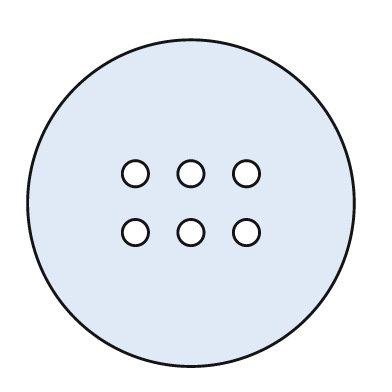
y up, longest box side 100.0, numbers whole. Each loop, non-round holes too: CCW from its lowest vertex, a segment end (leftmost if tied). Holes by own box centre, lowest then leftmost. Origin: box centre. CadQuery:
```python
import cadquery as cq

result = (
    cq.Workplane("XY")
    .moveTo(0.0, 0.0)
    .circle(50.0)
    .moveTo(-17.0, -9.0)
    .circle(4.0)
    .moveTo(0.0, -9.0)
    .circle(4.0)
    .moveTo(17.0, -9.0)
    .circle(4.0)
    .moveTo(-17.0, 9.0)
    .circle(4.0)
    .moveTo(0.0, 9.0)
    .circle(4.0)
    .moveTo(17.0, 9.0)
    .circle(4.0)
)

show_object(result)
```